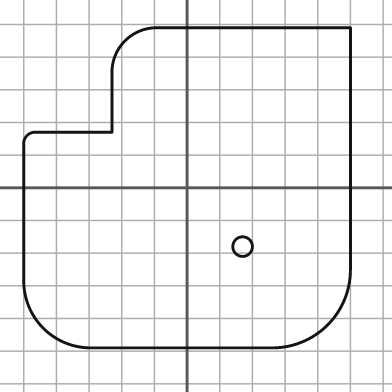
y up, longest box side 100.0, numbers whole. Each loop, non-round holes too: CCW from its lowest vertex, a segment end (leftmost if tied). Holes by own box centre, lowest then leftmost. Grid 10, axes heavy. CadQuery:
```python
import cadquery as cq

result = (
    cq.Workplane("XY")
    .moveTo(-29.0, -49.0)
    .lineTo(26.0, -49.0)
    .threePointArc((43.0, -42.0), (50.0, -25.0))
    .lineTo(50.0, 49.0)
    .lineTo(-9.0, 49.0)
    .threePointArc((-19.0, 45.0), (-23.0, 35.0))
    .lineTo(-23.0, 17.0)
    .lineTo(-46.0, 17.0)
    .threePointArc((-49.0, 16.0), (-50.0, 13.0))
    .lineTo(-50.0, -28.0)
    .threePointArc((-44.0, -43.0), (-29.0, -49.0))
    .close()
    .moveTo(17.0, -18.0)
    .circle(3.0)
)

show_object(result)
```